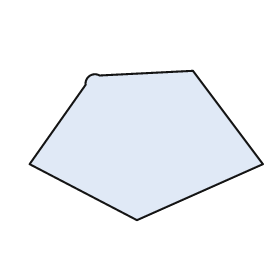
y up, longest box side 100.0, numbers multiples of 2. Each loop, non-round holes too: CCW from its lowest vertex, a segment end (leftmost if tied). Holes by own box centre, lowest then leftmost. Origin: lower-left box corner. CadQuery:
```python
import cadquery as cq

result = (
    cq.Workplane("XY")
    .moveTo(46.0, 0.0)
    .lineTo(100.0, 24.0)
    .lineTo(70.0, 64.0)
    .lineTo(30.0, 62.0)
    .threePointArc((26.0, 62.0), (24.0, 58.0))
    .lineTo(0.0, 24.0)
    .close()
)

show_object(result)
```